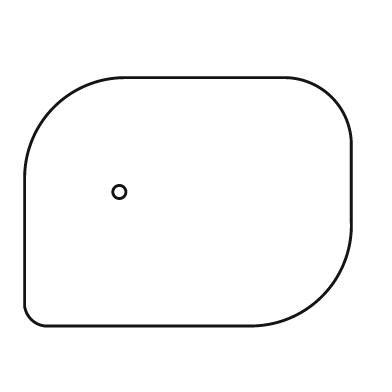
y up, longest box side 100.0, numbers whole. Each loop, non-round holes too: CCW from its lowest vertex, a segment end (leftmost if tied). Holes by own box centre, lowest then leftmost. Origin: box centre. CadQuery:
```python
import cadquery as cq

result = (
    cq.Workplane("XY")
    .moveTo(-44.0, -38.0)
    .lineTo(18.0, -38.0)
    .threePointArc((41.0, -29.0), (50.0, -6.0))
    .lineTo(50.0, 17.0)
    .threePointArc((44.0, 32.0), (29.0, 38.0))
    .lineTo(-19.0, 38.0)
    .threePointArc((-41.0, 29.0), (-50.0, 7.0))
    .lineTo(-50.0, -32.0)
    .threePointArc((-48.0, -36.0), (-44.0, -38.0))
    .close()
    .moveTo(-21.0, 3.0)
    .circle(2.0)
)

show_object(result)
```